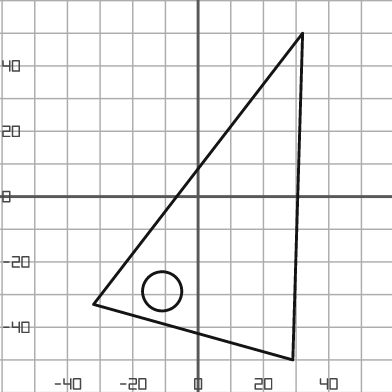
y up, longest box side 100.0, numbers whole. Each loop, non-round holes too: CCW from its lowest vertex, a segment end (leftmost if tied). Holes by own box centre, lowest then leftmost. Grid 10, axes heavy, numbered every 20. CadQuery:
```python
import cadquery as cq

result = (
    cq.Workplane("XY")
    .moveTo(29.0, -50.0)
    .lineTo(32.0, 50.0)
    .lineTo(-32.0, -33.0)
    .close()
    .moveTo(-11.0, -29.0)
    .circle(6.0)
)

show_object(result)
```